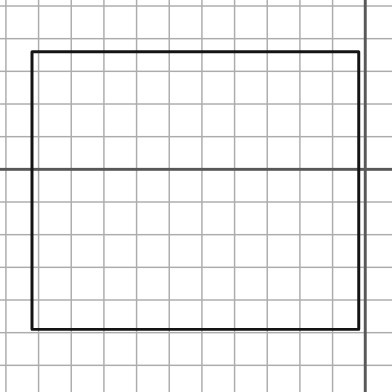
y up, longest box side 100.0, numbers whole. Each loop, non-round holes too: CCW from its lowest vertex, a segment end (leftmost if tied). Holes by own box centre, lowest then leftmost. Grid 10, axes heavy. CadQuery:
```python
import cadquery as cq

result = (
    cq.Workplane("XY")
    .moveTo(-102.0, -49.0)
    .lineTo(-2.0, -49.0)
    .lineTo(-2.0, 36.0)
    .lineTo(-102.0, 36.0)
    .close()
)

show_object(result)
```